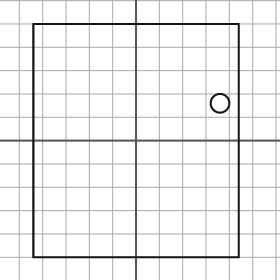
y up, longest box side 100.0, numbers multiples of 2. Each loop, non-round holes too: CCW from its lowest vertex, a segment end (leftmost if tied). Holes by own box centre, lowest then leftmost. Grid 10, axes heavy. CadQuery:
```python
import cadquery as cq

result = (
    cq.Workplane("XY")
    .moveTo(-44.0, -50.0)
    .lineTo(44.0, -50.0)
    .lineTo(44.0, 50.0)
    .lineTo(-44.0, 50.0)
    .close()
    .moveTo(36.0, 16.0)
    .circle(4.0)
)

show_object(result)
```